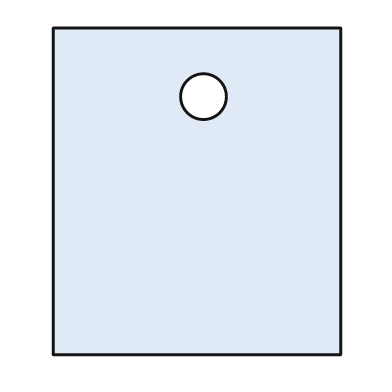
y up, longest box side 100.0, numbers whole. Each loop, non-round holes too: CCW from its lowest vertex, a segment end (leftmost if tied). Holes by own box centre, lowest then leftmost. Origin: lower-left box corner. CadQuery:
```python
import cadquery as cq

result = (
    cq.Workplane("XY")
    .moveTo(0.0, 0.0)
    .lineTo(88.0, 0.0)
    .lineTo(88.0, 100.0)
    .lineTo(0.0, 100.0)
    .close()
    .moveTo(46.0, 79.0)
    .circle(7.0)
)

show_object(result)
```